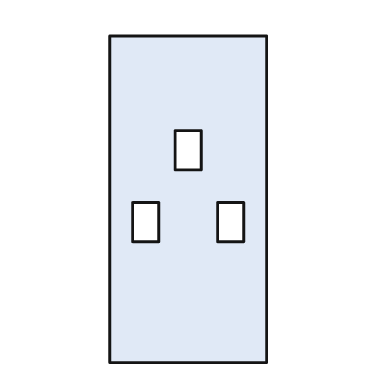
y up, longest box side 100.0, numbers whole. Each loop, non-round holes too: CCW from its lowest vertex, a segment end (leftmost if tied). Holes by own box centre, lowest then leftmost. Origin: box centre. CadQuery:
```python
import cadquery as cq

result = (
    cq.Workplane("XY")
    .moveTo(-24.0, -50.0)
    .lineTo(24.0, -50.0)
    .lineTo(24.0, 50.0)
    .lineTo(-24.0, 50.0)
    .close()
    .moveTo(-17.0, -13.0)
    .lineTo(-9.0, -13.0)
    .lineTo(-9.0, -1.0)
    .lineTo(-17.0, -1.0)
    .close()
    .moveTo(9.0, -13.0)
    .lineTo(17.0, -13.0)
    .lineTo(17.0, -1.0)
    .lineTo(9.0, -1.0)
    .close()
    .moveTo(-4.0, 9.0)
    .lineTo(4.0, 9.0)
    .lineTo(4.0, 21.0)
    .lineTo(-4.0, 21.0)
    .close()
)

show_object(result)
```